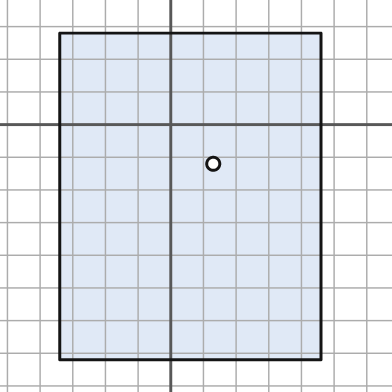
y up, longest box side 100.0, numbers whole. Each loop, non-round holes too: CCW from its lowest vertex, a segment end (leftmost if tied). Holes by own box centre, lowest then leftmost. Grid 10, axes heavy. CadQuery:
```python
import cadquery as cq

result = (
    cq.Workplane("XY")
    .moveTo(-34.0, -72.0)
    .lineTo(46.0, -72.0)
    .lineTo(46.0, 28.0)
    .lineTo(-34.0, 28.0)
    .close()
    .moveTo(13.0, -12.0)
    .circle(2.0)
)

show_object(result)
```